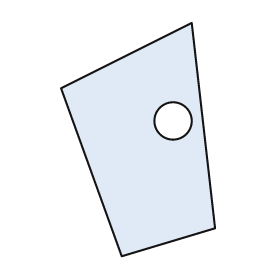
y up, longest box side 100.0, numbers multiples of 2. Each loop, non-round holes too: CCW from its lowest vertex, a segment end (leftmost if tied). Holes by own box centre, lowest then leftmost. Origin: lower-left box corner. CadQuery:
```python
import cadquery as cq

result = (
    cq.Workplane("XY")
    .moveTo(26.0, 0.0)
    .lineTo(66.0, 12.0)
    .lineTo(56.0, 100.0)
    .lineTo(0.0, 72.0)
    .close()
    .moveTo(48.0, 58.0)
    .circle(8.0)
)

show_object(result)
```